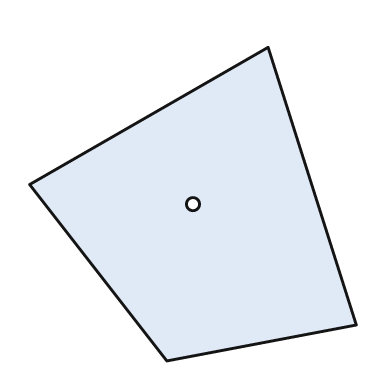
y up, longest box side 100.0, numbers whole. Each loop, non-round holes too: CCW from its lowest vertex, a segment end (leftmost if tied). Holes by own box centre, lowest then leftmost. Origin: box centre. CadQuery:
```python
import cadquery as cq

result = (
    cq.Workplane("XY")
    .moveTo(-8.0, -48.0)
    .lineTo(50.0, -37.0)
    .lineTo(23.0, 48.0)
    .lineTo(-50.0, 6.0)
    .close()
    .moveTo(0.0, 0.0)
    .circle(2.0)
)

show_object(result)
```